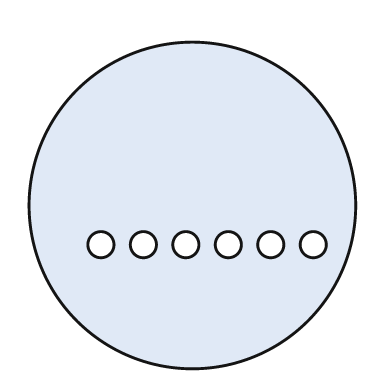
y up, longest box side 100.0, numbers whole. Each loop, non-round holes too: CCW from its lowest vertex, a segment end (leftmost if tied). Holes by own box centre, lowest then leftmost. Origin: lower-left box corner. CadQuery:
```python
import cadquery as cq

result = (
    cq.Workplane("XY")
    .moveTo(50.0, 50.0)
    .circle(50.0)
    .moveTo(22.0, 38.0)
    .circle(4.0)
    .moveTo(35.0, 38.0)
    .circle(4.0)
    .moveTo(48.0, 38.0)
    .circle(4.0)
    .moveTo(61.0, 38.0)
    .circle(4.0)
    .moveTo(74.0, 38.0)
    .circle(4.0)
    .moveTo(87.0, 38.0)
    .circle(4.0)
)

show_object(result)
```